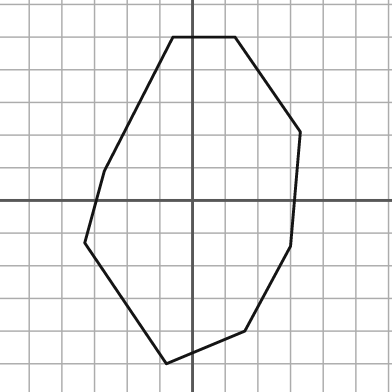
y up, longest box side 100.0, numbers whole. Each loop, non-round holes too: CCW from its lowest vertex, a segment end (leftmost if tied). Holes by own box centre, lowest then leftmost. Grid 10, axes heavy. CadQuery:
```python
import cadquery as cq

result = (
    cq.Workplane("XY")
    .moveTo(-8.0, -50.0)
    .lineTo(16.0, -40.0)
    .lineTo(30.0, -14.0)
    .lineTo(33.0, 21.0)
    .lineTo(13.0, 50.0)
    .lineTo(-6.0, 50.0)
    .lineTo(-27.0, 9.0)
    .lineTo(-33.0, -13.0)
    .close()
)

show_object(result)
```